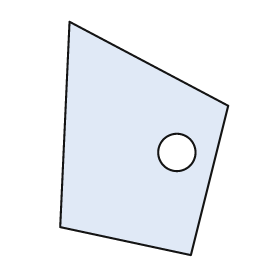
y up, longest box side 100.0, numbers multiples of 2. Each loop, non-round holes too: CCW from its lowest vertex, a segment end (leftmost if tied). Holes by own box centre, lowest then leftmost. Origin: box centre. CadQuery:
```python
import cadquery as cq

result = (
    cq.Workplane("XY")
    .moveTo(20.0, -50.0)
    .lineTo(36.0, 14.0)
    .lineTo(-32.0, 50.0)
    .lineTo(-36.0, -38.0)
    .close()
    .moveTo(14.0, -6.0)
    .circle(8.0)
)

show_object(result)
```